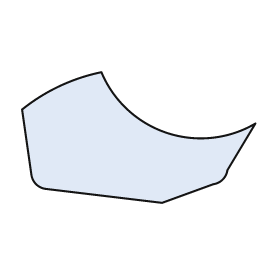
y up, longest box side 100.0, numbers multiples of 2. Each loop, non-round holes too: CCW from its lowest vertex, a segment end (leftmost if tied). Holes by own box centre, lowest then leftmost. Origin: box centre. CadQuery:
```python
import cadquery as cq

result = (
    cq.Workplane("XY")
    .moveTo(10.0, -28.0)
    .lineTo(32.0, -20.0)
    .threePointArc((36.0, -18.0), (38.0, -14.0))
    .lineTo(50.0, 6.0)
    .threePointArc((12.0, 2.0), (-16.0, 28.0))
    .threePointArc((-34.0, 22.0), (-50.0, 12.0))
    .lineTo(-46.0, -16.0)
    .threePointArc((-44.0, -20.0), (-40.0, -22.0))
    .close()
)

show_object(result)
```